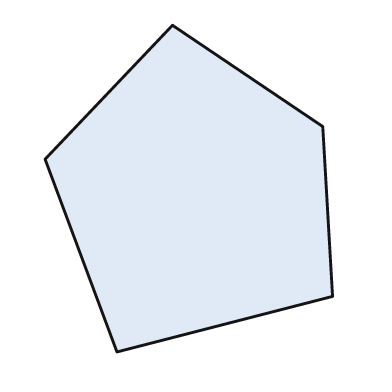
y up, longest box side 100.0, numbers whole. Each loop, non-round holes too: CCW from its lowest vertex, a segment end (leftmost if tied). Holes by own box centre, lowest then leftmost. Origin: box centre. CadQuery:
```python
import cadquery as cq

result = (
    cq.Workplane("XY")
    .moveTo(-22.0, -50.0)
    .lineTo(44.0, -33.0)
    .lineTo(41.0, 19.0)
    .lineTo(-5.0, 50.0)
    .lineTo(-44.0, 9.0)
    .close()
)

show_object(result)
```